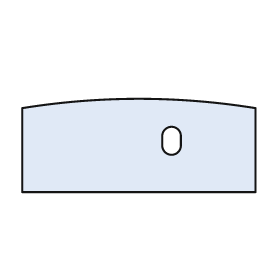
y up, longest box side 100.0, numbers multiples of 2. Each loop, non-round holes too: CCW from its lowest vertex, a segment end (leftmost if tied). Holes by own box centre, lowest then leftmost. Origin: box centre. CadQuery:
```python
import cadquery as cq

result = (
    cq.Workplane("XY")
    .moveTo(-50.0, -20.0)
    .lineTo(50.0, -20.0)
    .lineTo(50.0, 16.0)
    .threePointArc((0.0, 20.0), (-50.0, 16.0))
    .close()
    .moveTo(10.0, 0.0)
    .threePointArc((14.0, -4.0), (18.0, 0.0))
    .lineTo(18.0, 4.0)
    .threePointArc((14.0, 8.0), (10.0, 4.0))
    .close()
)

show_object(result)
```